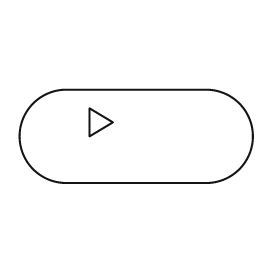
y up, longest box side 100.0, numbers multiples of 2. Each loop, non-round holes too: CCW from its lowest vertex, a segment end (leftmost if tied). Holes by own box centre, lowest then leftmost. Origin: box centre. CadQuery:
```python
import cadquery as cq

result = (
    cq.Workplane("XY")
    .moveTo(-30.0, -20.0)
    .lineTo(30.0, -20.0)
    .threePointArc((50.0, 0.0), (30.0, 20.0))
    .lineTo(-30.0, 20.0)
    .threePointArc((-50.0, 0.0), (-30.0, -20.0))
    .close()
    .moveTo(-20.0, 0.0)
    .lineTo(-10.0, 6.0)
    .lineTo(-20.0, 12.0)
    .close()
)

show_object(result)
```